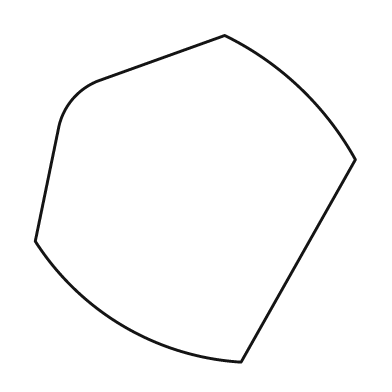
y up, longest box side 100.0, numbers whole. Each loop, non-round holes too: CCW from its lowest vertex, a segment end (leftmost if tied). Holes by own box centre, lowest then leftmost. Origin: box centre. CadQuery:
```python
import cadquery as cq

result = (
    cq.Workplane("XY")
    .moveTo(14.0, -50.0)
    .lineTo(49.0, 12.0)
    .threePointArc((32.0, 34.0), (9.0, 50.0))
    .lineTo(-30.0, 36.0)
    .threePointArc((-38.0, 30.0), (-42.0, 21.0))
    .lineTo(-49.0, -13.0)
    .threePointArc((-22.0, -39.0), (14.0, -50.0))
    .close()
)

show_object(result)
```